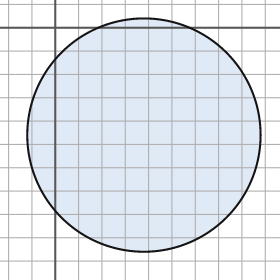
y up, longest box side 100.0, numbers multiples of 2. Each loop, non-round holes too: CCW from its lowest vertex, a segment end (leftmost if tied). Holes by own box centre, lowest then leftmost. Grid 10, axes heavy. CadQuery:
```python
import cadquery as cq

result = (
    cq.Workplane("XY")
    .moveTo(38.0, -46.0)
    .circle(50.0)
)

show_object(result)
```